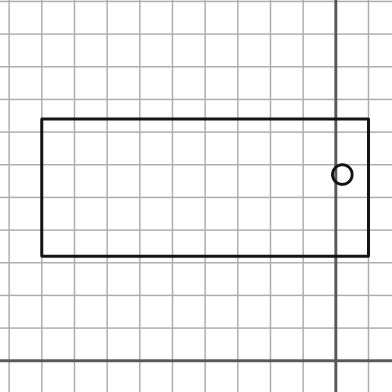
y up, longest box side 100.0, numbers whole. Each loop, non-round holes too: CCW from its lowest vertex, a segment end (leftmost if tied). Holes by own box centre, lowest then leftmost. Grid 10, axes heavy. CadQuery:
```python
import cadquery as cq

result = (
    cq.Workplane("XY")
    .moveTo(-90.0, 32.0)
    .lineTo(10.0, 32.0)
    .lineTo(10.0, 74.0)
    .lineTo(-90.0, 74.0)
    .close()
    .moveTo(2.0, 57.0)
    .circle(3.0)
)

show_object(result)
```